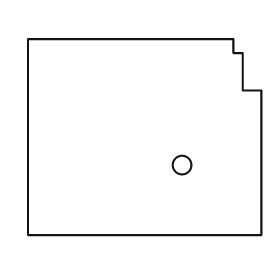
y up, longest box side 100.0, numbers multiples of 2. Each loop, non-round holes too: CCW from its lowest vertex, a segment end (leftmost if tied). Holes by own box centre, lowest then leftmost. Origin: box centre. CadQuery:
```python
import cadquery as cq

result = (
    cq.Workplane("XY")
    .moveTo(-50.0, -42.0)
    .lineTo(50.0, -42.0)
    .lineTo(50.0, 20.0)
    .lineTo(42.0, 20.0)
    .lineTo(42.0, 36.0)
    .lineTo(38.0, 36.0)
    .lineTo(38.0, 42.0)
    .lineTo(-50.0, 42.0)
    .close()
    .moveTo(16.0, -12.0)
    .circle(4.0)
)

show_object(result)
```